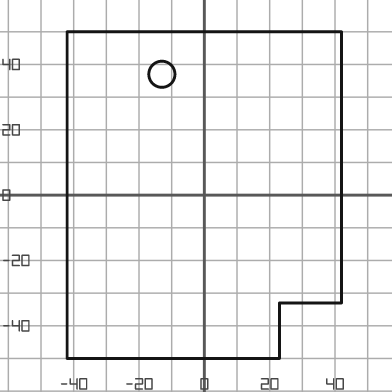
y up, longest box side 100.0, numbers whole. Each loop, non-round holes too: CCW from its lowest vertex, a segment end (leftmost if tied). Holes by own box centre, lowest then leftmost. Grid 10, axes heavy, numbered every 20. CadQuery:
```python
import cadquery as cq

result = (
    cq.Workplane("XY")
    .moveTo(-42.0, -50.0)
    .lineTo(23.0, -50.0)
    .lineTo(23.0, -33.0)
    .lineTo(42.0, -33.0)
    .lineTo(42.0, 50.0)
    .lineTo(-42.0, 50.0)
    .close()
    .moveTo(-13.0, 37.0)
    .circle(4.0)
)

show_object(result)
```